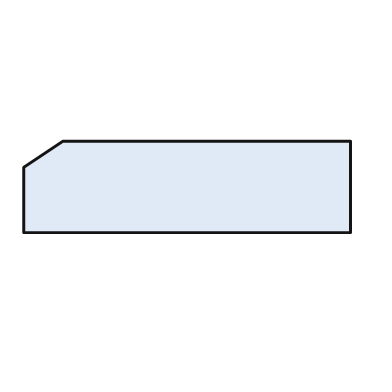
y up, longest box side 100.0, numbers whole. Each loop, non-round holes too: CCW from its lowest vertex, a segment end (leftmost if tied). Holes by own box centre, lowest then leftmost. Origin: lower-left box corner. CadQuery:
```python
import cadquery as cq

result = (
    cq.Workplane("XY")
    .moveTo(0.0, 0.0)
    .lineTo(100.0, 0.0)
    .lineTo(100.0, 28.0)
    .lineTo(12.0, 28.0)
    .lineTo(0.0, 20.0)
    .close()
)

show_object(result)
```